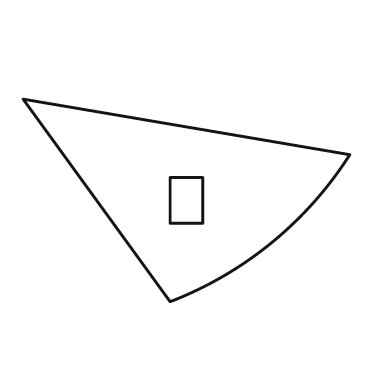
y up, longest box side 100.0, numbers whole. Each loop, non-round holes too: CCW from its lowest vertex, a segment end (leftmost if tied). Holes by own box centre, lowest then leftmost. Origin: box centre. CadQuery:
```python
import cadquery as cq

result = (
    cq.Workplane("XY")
    .moveTo(-5.0, -31.0)
    .threePointArc((26.0, -13.0), (50.0, 14.0))
    .lineTo(-50.0, 31.0)
    .close()
    .moveTo(-5.0, -7.0)
    .lineTo(5.0, -7.0)
    .lineTo(5.0, 7.0)
    .lineTo(-5.0, 7.0)
    .close()
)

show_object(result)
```